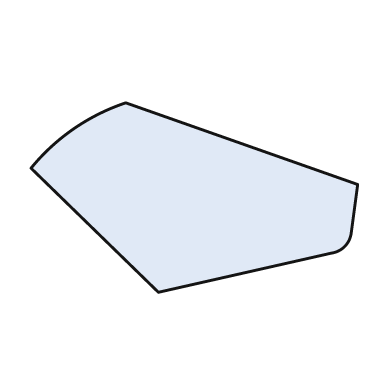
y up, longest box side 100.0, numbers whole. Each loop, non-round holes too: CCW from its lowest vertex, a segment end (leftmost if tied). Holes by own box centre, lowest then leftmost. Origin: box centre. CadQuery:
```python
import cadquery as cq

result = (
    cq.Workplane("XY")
    .moveTo(-11.0, -29.0)
    .lineTo(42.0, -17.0)
    .threePointArc((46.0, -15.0), (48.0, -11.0))
    .lineTo(50.0, 4.0)
    .lineTo(-21.0, 29.0)
    .threePointArc((-37.0, 21.0), (-50.0, 9.0))
    .close()
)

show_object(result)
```